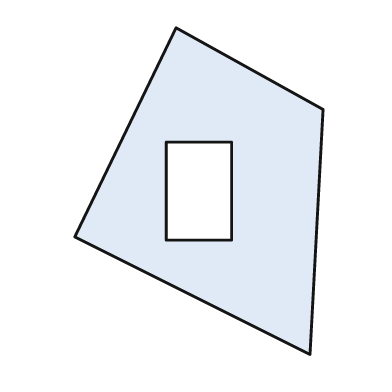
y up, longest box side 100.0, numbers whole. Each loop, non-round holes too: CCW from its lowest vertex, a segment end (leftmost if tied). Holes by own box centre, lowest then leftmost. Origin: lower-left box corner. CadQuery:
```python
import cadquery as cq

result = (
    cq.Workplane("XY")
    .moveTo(72.0, 0.0)
    .lineTo(76.0, 75.0)
    .lineTo(31.0, 100.0)
    .lineTo(0.0, 36.0)
    .close()
    .moveTo(28.0, 35.0)
    .lineTo(48.0, 35.0)
    .lineTo(48.0, 65.0)
    .lineTo(28.0, 65.0)
    .close()
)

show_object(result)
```